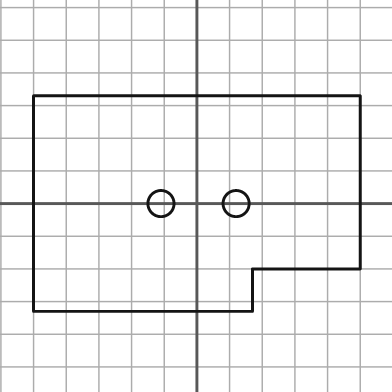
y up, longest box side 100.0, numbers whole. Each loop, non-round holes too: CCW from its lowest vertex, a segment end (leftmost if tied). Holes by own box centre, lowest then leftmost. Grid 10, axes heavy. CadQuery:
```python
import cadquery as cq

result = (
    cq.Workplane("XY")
    .moveTo(-50.0, -33.0)
    .lineTo(17.0, -33.0)
    .lineTo(17.0, -20.0)
    .lineTo(50.0, -20.0)
    .lineTo(50.0, 33.0)
    .lineTo(-50.0, 33.0)
    .close()
    .moveTo(-11.0, 0.0)
    .circle(4.0)
    .moveTo(12.0, 0.0)
    .circle(4.0)
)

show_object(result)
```